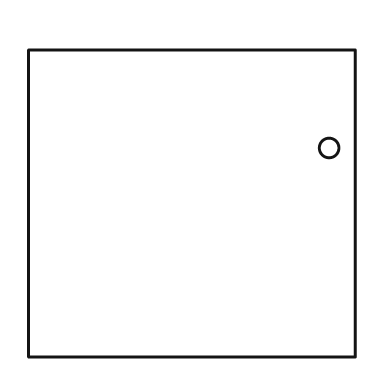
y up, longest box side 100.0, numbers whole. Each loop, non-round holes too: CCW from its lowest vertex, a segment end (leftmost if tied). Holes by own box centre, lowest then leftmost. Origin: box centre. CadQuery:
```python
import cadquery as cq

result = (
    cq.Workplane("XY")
    .moveTo(-50.0, -47.0)
    .lineTo(50.0, -47.0)
    .lineTo(50.0, 47.0)
    .lineTo(-50.0, 47.0)
    .close()
    .moveTo(42.0, 17.0)
    .circle(3.0)
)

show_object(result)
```